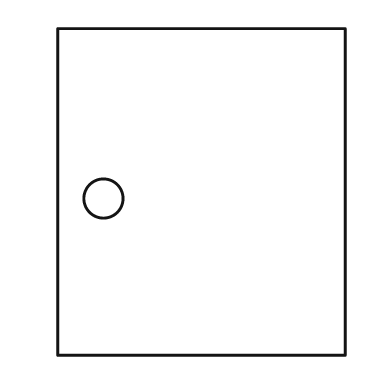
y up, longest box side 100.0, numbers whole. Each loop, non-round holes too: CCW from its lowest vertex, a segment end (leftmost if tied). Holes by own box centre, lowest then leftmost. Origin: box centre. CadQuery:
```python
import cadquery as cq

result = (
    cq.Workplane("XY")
    .moveTo(-44.0, -50.0)
    .lineTo(44.0, -50.0)
    .lineTo(44.0, 50.0)
    .lineTo(-44.0, 50.0)
    .close()
    .moveTo(-30.0, -2.0)
    .circle(6.0)
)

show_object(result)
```